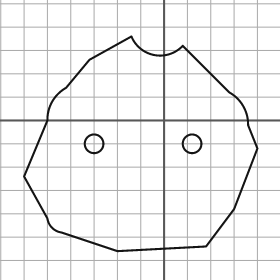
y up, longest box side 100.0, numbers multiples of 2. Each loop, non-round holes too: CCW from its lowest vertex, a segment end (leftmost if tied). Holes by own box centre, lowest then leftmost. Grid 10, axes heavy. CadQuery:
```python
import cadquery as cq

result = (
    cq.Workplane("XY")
    .moveTo(-20.0, -56.0)
    .lineTo(18.0, -54.0)
    .lineTo(30.0, -38.0)
    .lineTo(40.0, -12.0)
    .lineTo(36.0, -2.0)
    .threePointArc((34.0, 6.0), (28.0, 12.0))
    .lineTo(8.0, 32.0)
    .threePointArc((-4.0, 28.0), (-14.0, 36.0))
    .lineTo(-32.0, 26.0)
    .lineTo(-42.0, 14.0)
    .threePointArc((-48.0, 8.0), (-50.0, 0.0))
    .lineTo(-60.0, -24.0)
    .lineTo(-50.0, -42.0)
    .threePointArc((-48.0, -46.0), (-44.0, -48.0))
    .close()
    .moveTo(-30.0, -10.0)
    .circle(4.0)
    .moveTo(12.0, -10.0)
    .circle(4.0)
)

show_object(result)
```